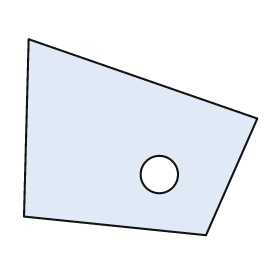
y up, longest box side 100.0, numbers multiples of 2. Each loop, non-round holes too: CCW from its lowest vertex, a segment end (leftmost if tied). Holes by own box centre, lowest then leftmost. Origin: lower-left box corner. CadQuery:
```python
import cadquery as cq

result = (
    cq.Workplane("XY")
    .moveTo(78.0, 0.0)
    .lineTo(100.0, 50.0)
    .lineTo(2.0, 84.0)
    .lineTo(0.0, 8.0)
    .close()
    .moveTo(58.0, 26.0)
    .circle(8.0)
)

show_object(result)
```